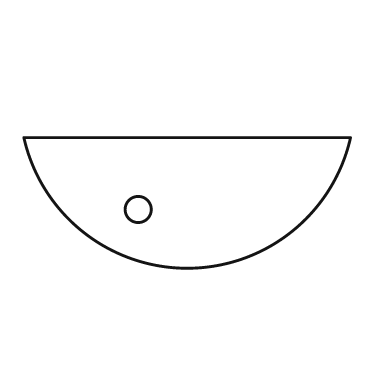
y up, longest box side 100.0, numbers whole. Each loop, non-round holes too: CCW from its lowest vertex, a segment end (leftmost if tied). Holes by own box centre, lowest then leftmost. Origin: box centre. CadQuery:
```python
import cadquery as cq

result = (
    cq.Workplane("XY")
    .moveTo(-50.0, 20.0)
    .threePointArc((0.0, -20.0), (50.0, 20.0))
    .close()
    .moveTo(-15.0, -2.0)
    .circle(4.0)
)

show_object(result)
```